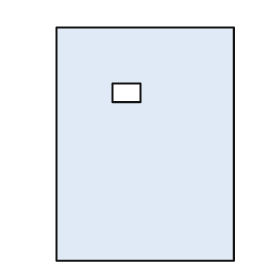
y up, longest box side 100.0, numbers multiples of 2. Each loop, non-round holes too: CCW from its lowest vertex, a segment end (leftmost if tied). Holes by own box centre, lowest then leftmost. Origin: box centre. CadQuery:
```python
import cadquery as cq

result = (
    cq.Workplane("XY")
    .moveTo(-38.0, -50.0)
    .lineTo(38.0, -50.0)
    .lineTo(38.0, 50.0)
    .lineTo(-38.0, 50.0)
    .close()
    .moveTo(-14.0, 18.0)
    .lineTo(-2.0, 18.0)
    .lineTo(-2.0, 26.0)
    .lineTo(-14.0, 26.0)
    .close()
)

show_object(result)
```